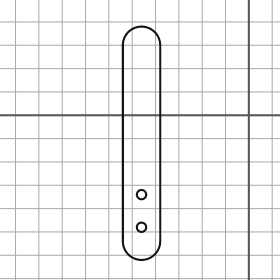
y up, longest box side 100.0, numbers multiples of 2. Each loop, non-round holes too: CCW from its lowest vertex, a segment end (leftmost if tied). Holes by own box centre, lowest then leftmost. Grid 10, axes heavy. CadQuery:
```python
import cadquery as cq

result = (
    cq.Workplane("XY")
    .moveTo(-54.0, -54.0)
    .threePointArc((-46.0, -62.0), (-38.0, -54.0))
    .lineTo(-38.0, 30.0)
    .threePointArc((-46.0, 38.0), (-54.0, 30.0))
    .close()
    .moveTo(-46.0, -48.0)
    .circle(2.0)
    .moveTo(-46.0, -34.0)
    .circle(2.0)
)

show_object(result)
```